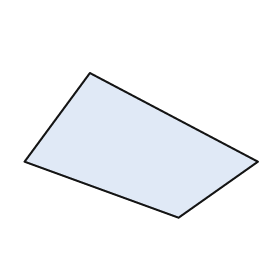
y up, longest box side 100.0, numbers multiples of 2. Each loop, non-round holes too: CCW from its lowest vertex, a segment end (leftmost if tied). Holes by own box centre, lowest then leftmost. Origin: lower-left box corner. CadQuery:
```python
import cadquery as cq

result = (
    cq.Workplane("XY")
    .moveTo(66.0, 0.0)
    .lineTo(100.0, 24.0)
    .lineTo(28.0, 62.0)
    .lineTo(0.0, 24.0)
    .close()
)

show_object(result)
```